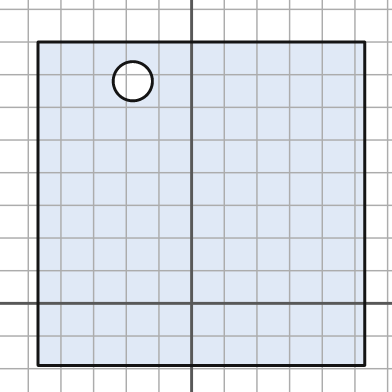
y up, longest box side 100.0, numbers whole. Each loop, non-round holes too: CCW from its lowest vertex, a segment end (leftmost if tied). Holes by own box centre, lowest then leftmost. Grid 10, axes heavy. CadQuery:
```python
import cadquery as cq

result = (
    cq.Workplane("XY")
    .moveTo(-47.0, -19.0)
    .lineTo(53.0, -19.0)
    .lineTo(53.0, 80.0)
    .lineTo(-47.0, 80.0)
    .close()
    .moveTo(-18.0, 68.0)
    .circle(6.0)
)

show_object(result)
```